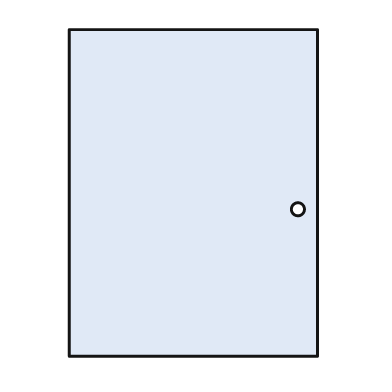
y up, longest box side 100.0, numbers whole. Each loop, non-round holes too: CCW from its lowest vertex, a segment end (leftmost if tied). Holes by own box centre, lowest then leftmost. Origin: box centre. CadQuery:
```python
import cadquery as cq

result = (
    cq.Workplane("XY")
    .moveTo(-38.0, -50.0)
    .lineTo(38.0, -50.0)
    .lineTo(38.0, 50.0)
    .lineTo(-38.0, 50.0)
    .close()
    .moveTo(32.0, -5.0)
    .circle(2.0)
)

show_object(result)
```